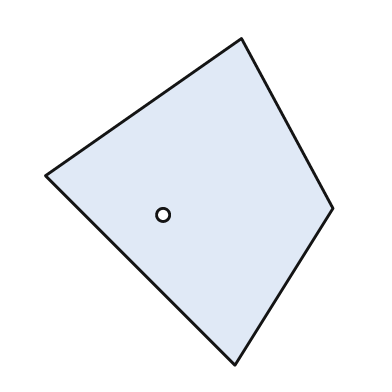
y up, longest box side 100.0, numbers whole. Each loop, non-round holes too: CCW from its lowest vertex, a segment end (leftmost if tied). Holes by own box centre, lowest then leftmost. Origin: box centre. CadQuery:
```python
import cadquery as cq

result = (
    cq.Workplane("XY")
    .moveTo(14.0, -50.0)
    .lineTo(44.0, -2.0)
    .lineTo(16.0, 50.0)
    .lineTo(-44.0, 8.0)
    .close()
    .moveTo(-8.0, -4.0)
    .circle(2.0)
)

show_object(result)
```